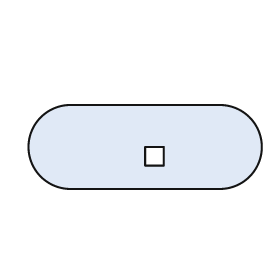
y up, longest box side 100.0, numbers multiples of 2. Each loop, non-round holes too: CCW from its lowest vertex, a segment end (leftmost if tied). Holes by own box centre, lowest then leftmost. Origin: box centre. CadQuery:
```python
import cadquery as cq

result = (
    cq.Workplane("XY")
    .moveTo(-32.0, -18.0)
    .lineTo(32.0, -18.0)
    .threePointArc((50.0, 0.0), (32.0, 18.0))
    .lineTo(-32.0, 18.0)
    .threePointArc((-50.0, 0.0), (-32.0, -18.0))
    .close()
    .moveTo(0.0, -8.0)
    .lineTo(8.0, -8.0)
    .lineTo(8.0, 0.0)
    .lineTo(0.0, 0.0)
    .close()
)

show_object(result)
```